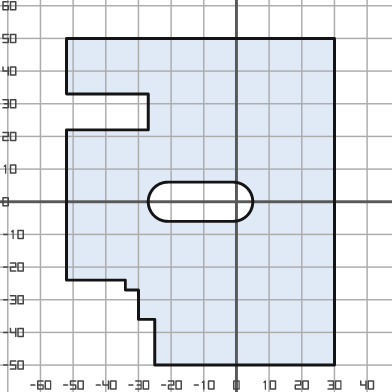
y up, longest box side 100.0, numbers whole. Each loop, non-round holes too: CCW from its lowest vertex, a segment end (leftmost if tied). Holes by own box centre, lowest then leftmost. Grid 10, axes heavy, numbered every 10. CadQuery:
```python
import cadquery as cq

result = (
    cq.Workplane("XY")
    .moveTo(-25.0, -50.0)
    .lineTo(30.0, -50.0)
    .lineTo(30.0, 50.0)
    .lineTo(-52.0, 50.0)
    .lineTo(-52.0, 33.0)
    .lineTo(-27.0, 33.0)
    .lineTo(-27.0, 22.0)
    .lineTo(-52.0, 22.0)
    .lineTo(-52.0, -24.0)
    .lineTo(-34.0, -24.0)
    .lineTo(-34.0, -27.0)
    .lineTo(-30.0, -27.0)
    .lineTo(-30.0, -36.0)
    .lineTo(-25.0, -36.0)
    .close()
    .moveTo(-21.0, -6.0)
    .lineTo(-1.0, -6.0)
    .threePointArc((5.0, 0.0), (-1.0, 6.0))
    .lineTo(-21.0, 6.0)
    .threePointArc((-27.0, 0.0), (-21.0, -6.0))
    .close()
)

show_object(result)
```